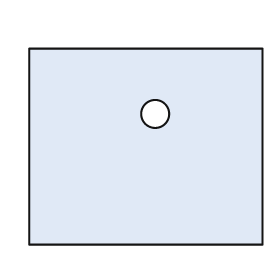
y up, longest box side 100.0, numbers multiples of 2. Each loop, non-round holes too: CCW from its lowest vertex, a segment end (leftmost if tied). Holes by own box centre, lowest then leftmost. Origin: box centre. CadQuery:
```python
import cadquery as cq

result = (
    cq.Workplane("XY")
    .moveTo(-50.0, -42.0)
    .lineTo(50.0, -42.0)
    .lineTo(50.0, 42.0)
    .lineTo(-50.0, 42.0)
    .close()
    .moveTo(4.0, 14.0)
    .circle(6.0)
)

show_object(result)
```